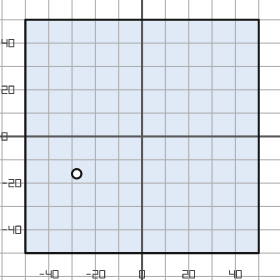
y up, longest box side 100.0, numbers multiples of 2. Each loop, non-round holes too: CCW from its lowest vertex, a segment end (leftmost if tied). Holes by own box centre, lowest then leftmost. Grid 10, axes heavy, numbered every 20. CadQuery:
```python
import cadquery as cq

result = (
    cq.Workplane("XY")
    .moveTo(-50.0, -50.0)
    .lineTo(50.0, -50.0)
    .lineTo(50.0, 50.0)
    .lineTo(-50.0, 50.0)
    .close()
    .moveTo(-28.0, -16.0)
    .circle(2.0)
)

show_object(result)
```